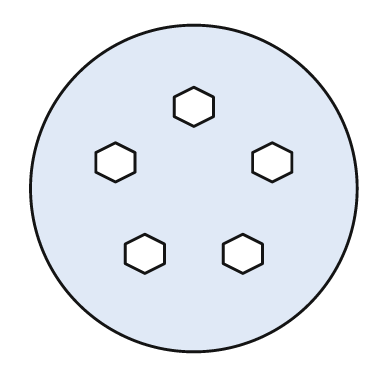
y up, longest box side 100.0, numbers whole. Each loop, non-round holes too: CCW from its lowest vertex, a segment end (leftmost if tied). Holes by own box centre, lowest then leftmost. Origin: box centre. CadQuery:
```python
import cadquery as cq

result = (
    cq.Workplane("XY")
    .moveTo(0.0, 0.0)
    .circle(50.0)
    .moveTo(-15.0, -26.0)
    .lineTo(-9.0, -23.0)
    .lineTo(-9.0, -17.0)
    .lineTo(-15.0, -14.0)
    .lineTo(-21.0, -17.0)
    .lineTo(-21.0, -23.0)
    .close()
    .moveTo(15.0, -26.0)
    .lineTo(21.0, -23.0)
    .lineTo(21.0, -17.0)
    .lineTo(15.0, -14.0)
    .lineTo(9.0, -17.0)
    .lineTo(9.0, -23.0)
    .close()
    .moveTo(-24.0, 2.0)
    .lineTo(-18.0, 5.0)
    .lineTo(-18.0, 11.0)
    .lineTo(-24.0, 14.0)
    .lineTo(-30.0, 11.0)
    .lineTo(-30.0, 5.0)
    .close()
    .moveTo(24.0, 2.0)
    .lineTo(30.0, 5.0)
    .lineTo(30.0, 11.0)
    .lineTo(24.0, 14.0)
    .lineTo(18.0, 11.0)
    .lineTo(18.0, 5.0)
    .close()
    .moveTo(0.0, 19.0)
    .lineTo(6.0, 22.0)
    .lineTo(6.0, 28.0)
    .lineTo(0.0, 31.0)
    .lineTo(-6.0, 28.0)
    .lineTo(-6.0, 22.0)
    .close()
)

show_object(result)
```